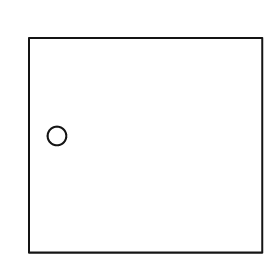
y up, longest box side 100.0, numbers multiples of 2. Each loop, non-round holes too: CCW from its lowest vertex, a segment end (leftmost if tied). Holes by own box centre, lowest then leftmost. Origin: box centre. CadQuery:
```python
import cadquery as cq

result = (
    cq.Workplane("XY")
    .moveTo(-50.0, -46.0)
    .lineTo(50.0, -46.0)
    .lineTo(50.0, 46.0)
    .lineTo(-50.0, 46.0)
    .close()
    .moveTo(-38.0, 4.0)
    .circle(4.0)
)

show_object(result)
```